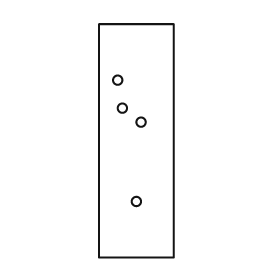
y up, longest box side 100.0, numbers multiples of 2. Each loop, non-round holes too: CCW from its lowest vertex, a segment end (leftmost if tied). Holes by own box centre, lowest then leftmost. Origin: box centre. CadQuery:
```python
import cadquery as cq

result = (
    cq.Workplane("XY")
    .moveTo(-16.0, -50.0)
    .lineTo(16.0, -50.0)
    .lineTo(16.0, 50.0)
    .lineTo(-16.0, 50.0)
    .close()
    .moveTo(0.0, -26.0)
    .circle(2.0)
    .moveTo(2.0, 8.0)
    .circle(2.0)
    .moveTo(-6.0, 14.0)
    .circle(2.0)
    .moveTo(-8.0, 26.0)
    .circle(2.0)
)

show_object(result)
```